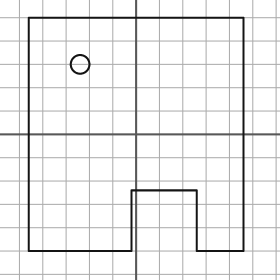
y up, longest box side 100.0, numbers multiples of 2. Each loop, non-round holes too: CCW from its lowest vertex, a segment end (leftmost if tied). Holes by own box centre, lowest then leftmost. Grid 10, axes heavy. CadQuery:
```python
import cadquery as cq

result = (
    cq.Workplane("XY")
    .moveTo(-46.0, -50.0)
    .lineTo(-2.0, -50.0)
    .lineTo(-2.0, -24.0)
    .lineTo(26.0, -24.0)
    .lineTo(26.0, -50.0)
    .lineTo(46.0, -50.0)
    .lineTo(46.0, 50.0)
    .lineTo(-46.0, 50.0)
    .close()
    .moveTo(-24.0, 30.0)
    .circle(4.0)
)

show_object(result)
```